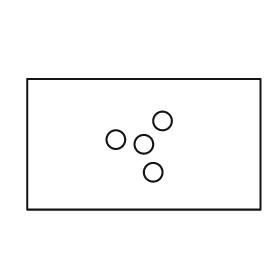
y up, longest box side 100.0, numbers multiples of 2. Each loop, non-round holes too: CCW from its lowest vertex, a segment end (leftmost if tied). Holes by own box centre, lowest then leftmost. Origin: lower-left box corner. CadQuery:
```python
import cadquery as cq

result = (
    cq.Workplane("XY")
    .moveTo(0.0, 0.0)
    .lineTo(100.0, 0.0)
    .lineTo(100.0, 56.0)
    .lineTo(0.0, 56.0)
    .close()
    .moveTo(54.0, 16.0)
    .circle(4.0)
    .moveTo(50.0, 28.0)
    .circle(4.0)
    .moveTo(38.0, 30.0)
    .circle(4.0)
    .moveTo(58.0, 38.0)
    .circle(4.0)
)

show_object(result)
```